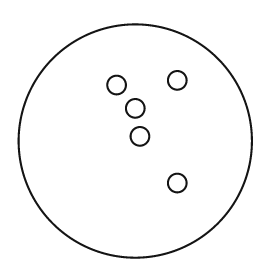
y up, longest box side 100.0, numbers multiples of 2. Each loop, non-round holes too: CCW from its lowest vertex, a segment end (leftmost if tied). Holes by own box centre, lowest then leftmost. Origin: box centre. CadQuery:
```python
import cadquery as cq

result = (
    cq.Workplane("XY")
    .moveTo(0.0, 0.0)
    .circle(50.0)
    .moveTo(18.0, -18.0)
    .circle(4.0)
    .moveTo(2.0, 2.0)
    .circle(4.0)
    .moveTo(0.0, 14.0)
    .circle(4.0)
    .moveTo(-8.0, 24.0)
    .circle(4.0)
    .moveTo(18.0, 26.0)
    .circle(4.0)
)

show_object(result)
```